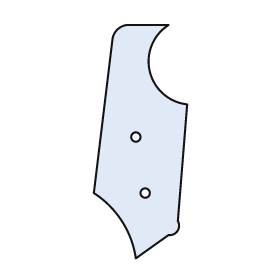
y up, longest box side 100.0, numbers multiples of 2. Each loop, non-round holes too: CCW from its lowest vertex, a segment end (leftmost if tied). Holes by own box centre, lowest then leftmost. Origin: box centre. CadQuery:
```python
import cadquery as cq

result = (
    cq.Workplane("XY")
    .moveTo(-2.0, -50.0)
    .lineTo(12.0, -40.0)
    .threePointArc((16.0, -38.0), (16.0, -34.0))
    .lineTo(20.0, 16.0)
    .threePointArc((4.0, 30.0), (12.0, 50.0))
    .lineTo(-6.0, 50.0)
    .threePointArc((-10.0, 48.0), (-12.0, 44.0))
    .lineTo(-20.0, -22.0)
    .threePointArc((-8.0, -34.0), (-2.0, -50.0))
    .close()
    .moveTo(2.0, -22.0)
    .circle(2.0)
    .moveTo(-2.0, 2.0)
    .circle(2.0)
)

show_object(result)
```